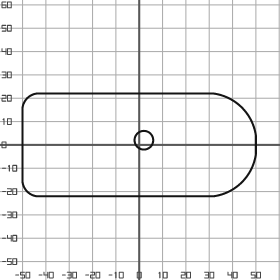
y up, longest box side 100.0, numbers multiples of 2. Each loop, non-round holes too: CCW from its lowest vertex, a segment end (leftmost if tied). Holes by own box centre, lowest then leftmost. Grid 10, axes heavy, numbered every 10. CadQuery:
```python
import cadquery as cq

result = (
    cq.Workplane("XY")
    .moveTo(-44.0, -22.0)
    .lineTo(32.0, -22.0)
    .threePointArc((44.0, -16.0), (50.0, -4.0))
    .lineTo(50.0, 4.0)
    .threePointArc((44.0, 16.0), (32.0, 22.0))
    .lineTo(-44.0, 22.0)
    .threePointArc((-48.0, 20.0), (-50.0, 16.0))
    .lineTo(-50.0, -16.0)
    .threePointArc((-48.0, -20.0), (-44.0, -22.0))
    .close()
    .moveTo(2.0, 2.0)
    .circle(4.0)
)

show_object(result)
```